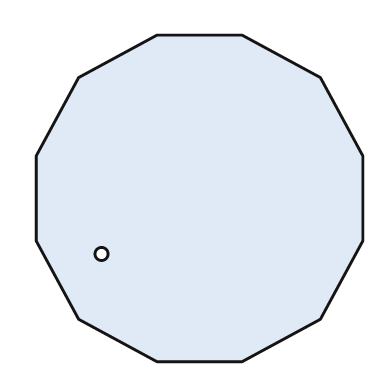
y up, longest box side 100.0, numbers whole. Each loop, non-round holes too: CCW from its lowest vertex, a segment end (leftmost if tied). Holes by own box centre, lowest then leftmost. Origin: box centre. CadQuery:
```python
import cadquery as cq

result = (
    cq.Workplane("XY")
    .moveTo(-13.0, -50.0)
    .lineTo(13.0, -50.0)
    .lineTo(37.0, -37.0)
    .lineTo(50.0, -13.0)
    .lineTo(50.0, 13.0)
    .lineTo(37.0, 37.0)
    .lineTo(13.0, 50.0)
    .lineTo(-13.0, 50.0)
    .lineTo(-37.0, 37.0)
    .lineTo(-50.0, 13.0)
    .lineTo(-50.0, -13.0)
    .lineTo(-37.0, -37.0)
    .close()
    .moveTo(-30.0, -17.0)
    .circle(2.0)
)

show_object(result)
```